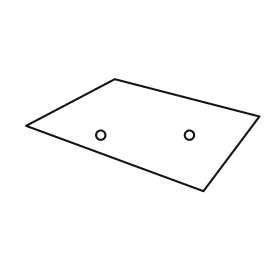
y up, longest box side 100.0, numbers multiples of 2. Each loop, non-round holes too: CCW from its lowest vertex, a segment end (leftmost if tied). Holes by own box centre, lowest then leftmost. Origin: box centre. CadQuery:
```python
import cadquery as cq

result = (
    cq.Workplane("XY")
    .moveTo(26.0, -24.0)
    .lineTo(50.0, 8.0)
    .lineTo(-12.0, 24.0)
    .lineTo(-50.0, 4.0)
    .close()
    .moveTo(-18.0, 0.0)
    .circle(2.0)
    .moveTo(20.0, 0.0)
    .circle(2.0)
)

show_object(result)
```